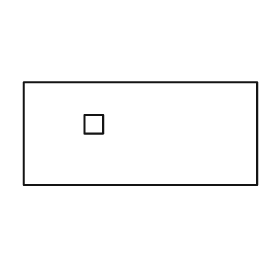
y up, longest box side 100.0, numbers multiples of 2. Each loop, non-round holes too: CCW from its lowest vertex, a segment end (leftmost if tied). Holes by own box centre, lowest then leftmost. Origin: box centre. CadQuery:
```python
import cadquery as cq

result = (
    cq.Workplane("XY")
    .moveTo(-50.0, -22.0)
    .lineTo(50.0, -22.0)
    .lineTo(50.0, 22.0)
    .lineTo(-50.0, 22.0)
    .close()
    .moveTo(-24.0, 0.0)
    .lineTo(-16.0, 0.0)
    .lineTo(-16.0, 8.0)
    .lineTo(-24.0, 8.0)
    .close()
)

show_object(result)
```